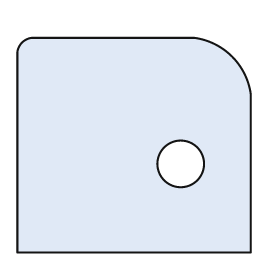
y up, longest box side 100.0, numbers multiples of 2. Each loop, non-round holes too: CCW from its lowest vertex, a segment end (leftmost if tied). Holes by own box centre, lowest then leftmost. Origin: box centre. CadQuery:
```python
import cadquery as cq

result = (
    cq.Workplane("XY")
    .moveTo(-50.0, -46.0)
    .lineTo(50.0, -46.0)
    .lineTo(50.0, 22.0)
    .threePointArc((42.0, 38.0), (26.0, 46.0))
    .lineTo(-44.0, 46.0)
    .threePointArc((-48.0, 44.0), (-50.0, 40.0))
    .close()
    .moveTo(20.0, -8.0)
    .circle(10.0)
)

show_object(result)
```